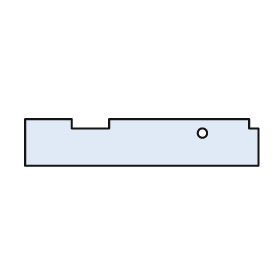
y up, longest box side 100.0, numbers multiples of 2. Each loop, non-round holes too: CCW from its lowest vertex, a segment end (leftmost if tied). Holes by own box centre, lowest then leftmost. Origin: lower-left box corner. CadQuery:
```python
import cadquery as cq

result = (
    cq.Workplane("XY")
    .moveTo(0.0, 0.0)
    .lineTo(100.0, 0.0)
    .lineTo(100.0, 16.0)
    .lineTo(96.0, 16.0)
    .lineTo(96.0, 20.0)
    .lineTo(36.0, 20.0)
    .lineTo(36.0, 16.0)
    .lineTo(20.0, 16.0)
    .lineTo(20.0, 20.0)
    .lineTo(0.0, 20.0)
    .close()
    .moveTo(76.0, 14.0)
    .circle(2.0)
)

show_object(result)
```